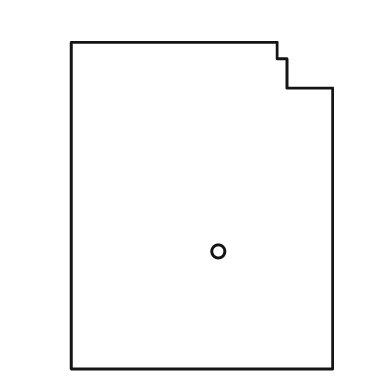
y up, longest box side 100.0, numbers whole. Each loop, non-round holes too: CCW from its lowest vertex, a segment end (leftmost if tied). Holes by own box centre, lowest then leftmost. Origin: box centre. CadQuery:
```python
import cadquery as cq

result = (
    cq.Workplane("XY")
    .moveTo(-40.0, -50.0)
    .lineTo(40.0, -50.0)
    .lineTo(40.0, 36.0)
    .lineTo(26.0, 36.0)
    .lineTo(26.0, 45.0)
    .lineTo(23.0, 45.0)
    .lineTo(23.0, 50.0)
    .lineTo(-40.0, 50.0)
    .close()
    .moveTo(5.0, -14.0)
    .circle(2.0)
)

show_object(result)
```